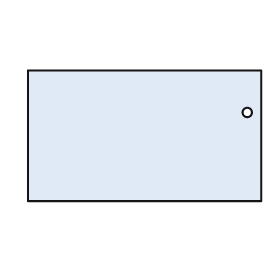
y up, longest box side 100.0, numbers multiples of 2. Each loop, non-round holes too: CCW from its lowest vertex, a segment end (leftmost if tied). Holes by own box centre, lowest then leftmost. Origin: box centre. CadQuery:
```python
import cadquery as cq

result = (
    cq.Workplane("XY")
    .moveTo(-50.0, -28.0)
    .lineTo(50.0, -28.0)
    .lineTo(50.0, 28.0)
    .lineTo(-50.0, 28.0)
    .close()
    .moveTo(44.0, 10.0)
    .circle(2.0)
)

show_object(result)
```